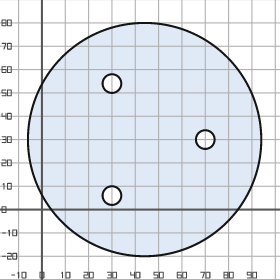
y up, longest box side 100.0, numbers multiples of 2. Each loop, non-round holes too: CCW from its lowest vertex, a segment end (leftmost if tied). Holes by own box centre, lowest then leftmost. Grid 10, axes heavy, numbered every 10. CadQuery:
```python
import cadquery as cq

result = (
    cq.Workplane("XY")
    .moveTo(44.0, 30.0)
    .circle(50.0)
    .moveTo(30.0, 6.0)
    .circle(4.0)
    .moveTo(70.0, 30.0)
    .circle(4.0)
    .moveTo(30.0, 54.0)
    .circle(4.0)
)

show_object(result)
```